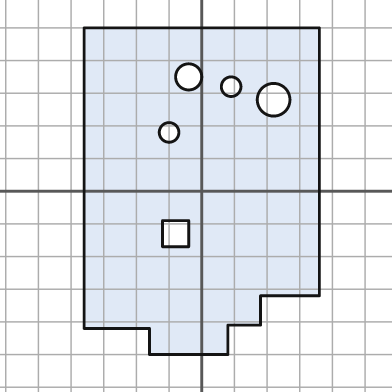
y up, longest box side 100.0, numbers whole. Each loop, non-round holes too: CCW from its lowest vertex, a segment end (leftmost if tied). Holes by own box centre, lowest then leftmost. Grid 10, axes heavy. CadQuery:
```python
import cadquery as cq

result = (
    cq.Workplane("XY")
    .moveTo(-16.0, -50.0)
    .lineTo(8.0, -50.0)
    .lineTo(8.0, -41.0)
    .lineTo(18.0, -41.0)
    .lineTo(18.0, -32.0)
    .lineTo(36.0, -32.0)
    .lineTo(36.0, 50.0)
    .lineTo(-36.0, 50.0)
    .lineTo(-36.0, -42.0)
    .lineTo(-16.0, -42.0)
    .close()
    .moveTo(-12.0, -17.0)
    .lineTo(-4.0, -17.0)
    .lineTo(-4.0, -9.0)
    .lineTo(-12.0, -9.0)
    .close()
    .moveTo(-10.0, 18.0)
    .circle(3.0)
    .moveTo(22.0, 28.0)
    .circle(5.0)
    .moveTo(9.0, 32.0)
    .circle(3.0)
    .moveTo(-4.0, 35.0)
    .circle(4.0)
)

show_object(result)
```